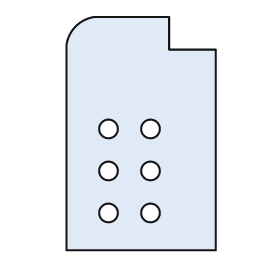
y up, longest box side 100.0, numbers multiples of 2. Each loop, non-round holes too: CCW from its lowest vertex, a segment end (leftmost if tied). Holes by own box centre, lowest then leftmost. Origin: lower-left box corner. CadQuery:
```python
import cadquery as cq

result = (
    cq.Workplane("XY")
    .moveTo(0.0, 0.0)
    .lineTo(64.0, 0.0)
    .lineTo(64.0, 86.0)
    .lineTo(44.0, 86.0)
    .lineTo(44.0, 100.0)
    .lineTo(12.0, 100.0)
    .threePointArc((4.0, 96.0), (0.0, 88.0))
    .close()
    .moveTo(18.0, 16.0)
    .circle(4.0)
    .moveTo(36.0, 16.0)
    .circle(4.0)
    .moveTo(18.0, 34.0)
    .circle(4.0)
    .moveTo(36.0, 34.0)
    .circle(4.0)
    .moveTo(18.0, 52.0)
    .circle(4.0)
    .moveTo(36.0, 52.0)
    .circle(4.0)
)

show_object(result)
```